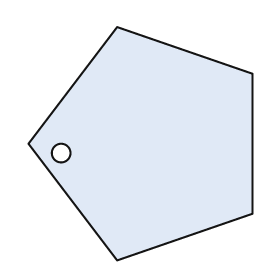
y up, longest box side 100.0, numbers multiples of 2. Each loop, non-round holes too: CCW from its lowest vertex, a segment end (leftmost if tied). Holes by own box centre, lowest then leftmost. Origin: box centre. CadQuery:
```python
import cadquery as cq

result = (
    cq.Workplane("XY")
    .moveTo(-10.0, -50.0)
    .lineTo(48.0, -30.0)
    .lineTo(48.0, 30.0)
    .lineTo(-10.0, 50.0)
    .lineTo(-48.0, 0.0)
    .close()
    .moveTo(-34.0, -4.0)
    .circle(4.0)
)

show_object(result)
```